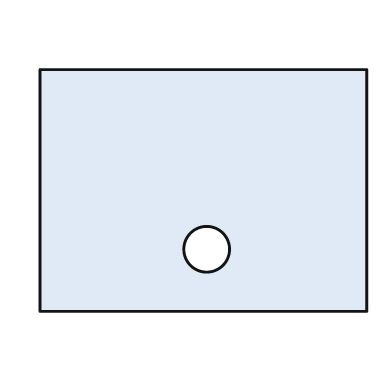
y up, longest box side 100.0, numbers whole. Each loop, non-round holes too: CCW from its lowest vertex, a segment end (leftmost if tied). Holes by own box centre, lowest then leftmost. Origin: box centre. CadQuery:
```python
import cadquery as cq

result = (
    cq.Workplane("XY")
    .moveTo(-50.0, -37.0)
    .lineTo(50.0, -37.0)
    .lineTo(50.0, 37.0)
    .lineTo(-50.0, 37.0)
    .close()
    .moveTo(1.0, -18.0)
    .circle(7.0)
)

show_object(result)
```